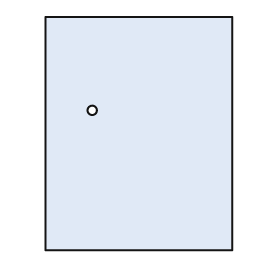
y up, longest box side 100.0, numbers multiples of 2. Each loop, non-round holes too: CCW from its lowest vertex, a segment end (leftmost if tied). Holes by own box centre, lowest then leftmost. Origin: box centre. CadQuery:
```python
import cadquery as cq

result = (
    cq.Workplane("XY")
    .moveTo(-40.0, -50.0)
    .lineTo(40.0, -50.0)
    .lineTo(40.0, 50.0)
    .lineTo(-40.0, 50.0)
    .close()
    .moveTo(-20.0, 10.0)
    .circle(2.0)
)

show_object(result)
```